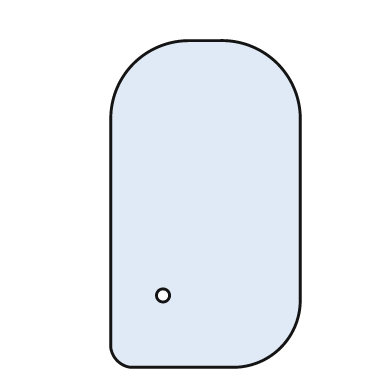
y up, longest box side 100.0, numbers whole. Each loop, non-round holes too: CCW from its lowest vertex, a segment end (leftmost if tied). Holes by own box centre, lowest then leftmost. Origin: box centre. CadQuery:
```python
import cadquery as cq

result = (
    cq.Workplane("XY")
    .moveTo(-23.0, -50.0)
    .lineTo(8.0, -50.0)
    .threePointArc((23.0, -44.0), (29.0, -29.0))
    .lineTo(29.0, 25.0)
    .threePointArc((22.0, 43.0), (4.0, 50.0))
    .lineTo(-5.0, 50.0)
    .threePointArc((-22.0, 43.0), (-29.0, 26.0))
    .lineTo(-29.0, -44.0)
    .threePointArc((-27.0, -48.0), (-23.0, -50.0))
    .close()
    .moveTo(-13.0, -28.0)
    .circle(2.0)
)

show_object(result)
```